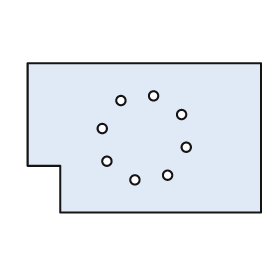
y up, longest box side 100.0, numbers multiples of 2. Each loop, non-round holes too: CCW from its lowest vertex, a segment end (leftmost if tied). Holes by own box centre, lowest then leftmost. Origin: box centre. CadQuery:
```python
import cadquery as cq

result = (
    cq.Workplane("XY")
    .moveTo(-36.0, -32.0)
    .lineTo(50.0, -32.0)
    .lineTo(50.0, 32.0)
    .lineTo(-50.0, 32.0)
    .lineTo(-50.0, -12.0)
    .lineTo(-36.0, -12.0)
    .close()
    .moveTo(-4.0, -18.0)
    .circle(2.0)
    .moveTo(10.0, -16.0)
    .circle(2.0)
    .moveTo(-16.0, -10.0)
    .circle(2.0)
    .moveTo(18.0, -4.0)
    .circle(2.0)
    .moveTo(-18.0, 4.0)
    .circle(2.0)
    .moveTo(16.0, 10.0)
    .circle(2.0)
    .moveTo(-10.0, 16.0)
    .circle(2.0)
    .moveTo(4.0, 18.0)
    .circle(2.0)
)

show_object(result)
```